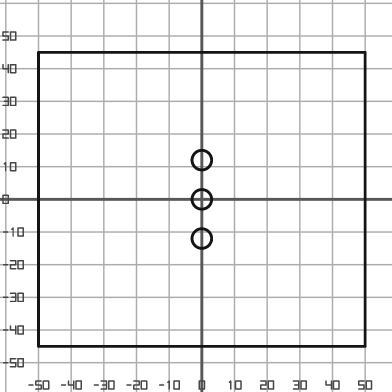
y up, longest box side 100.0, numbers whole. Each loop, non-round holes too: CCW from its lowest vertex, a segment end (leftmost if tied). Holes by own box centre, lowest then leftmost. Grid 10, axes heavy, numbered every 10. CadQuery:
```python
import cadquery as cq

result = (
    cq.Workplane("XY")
    .moveTo(-50.0, -45.0)
    .lineTo(50.0, -45.0)
    .lineTo(50.0, 45.0)
    .lineTo(-50.0, 45.0)
    .close()
    .moveTo(0.0, -12.0)
    .circle(3.0)
    .moveTo(0.0, 0.0)
    .circle(3.0)
    .moveTo(0.0, 12.0)
    .circle(3.0)
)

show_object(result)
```